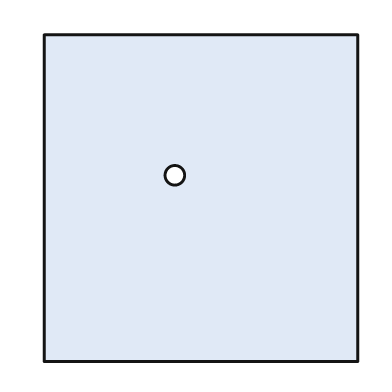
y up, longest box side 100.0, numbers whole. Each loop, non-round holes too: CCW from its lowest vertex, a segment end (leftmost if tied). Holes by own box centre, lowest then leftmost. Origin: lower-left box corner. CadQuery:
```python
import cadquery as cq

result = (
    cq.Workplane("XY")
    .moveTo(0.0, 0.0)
    .lineTo(96.0, 0.0)
    .lineTo(96.0, 100.0)
    .lineTo(0.0, 100.0)
    .close()
    .moveTo(40.0, 57.0)
    .circle(3.0)
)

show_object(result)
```